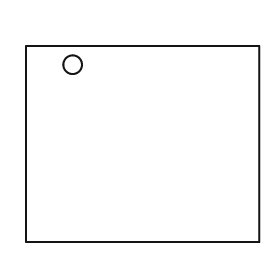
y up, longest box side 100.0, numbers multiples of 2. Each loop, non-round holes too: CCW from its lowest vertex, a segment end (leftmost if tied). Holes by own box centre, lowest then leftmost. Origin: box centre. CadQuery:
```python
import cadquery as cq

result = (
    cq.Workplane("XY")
    .moveTo(-50.0, -42.0)
    .lineTo(50.0, -42.0)
    .lineTo(50.0, 42.0)
    .lineTo(-50.0, 42.0)
    .close()
    .moveTo(-30.0, 34.0)
    .circle(4.0)
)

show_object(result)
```